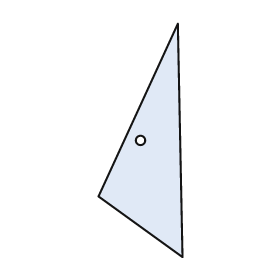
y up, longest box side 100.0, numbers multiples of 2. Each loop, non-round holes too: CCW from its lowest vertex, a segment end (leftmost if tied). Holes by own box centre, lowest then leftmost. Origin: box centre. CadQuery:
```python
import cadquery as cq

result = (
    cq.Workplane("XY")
    .moveTo(18.0, -50.0)
    .lineTo(16.0, 50.0)
    .lineTo(-18.0, -24.0)
    .close()
    .moveTo(0.0, 0.0)
    .circle(2.0)
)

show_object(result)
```